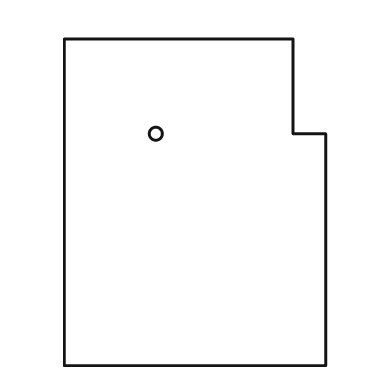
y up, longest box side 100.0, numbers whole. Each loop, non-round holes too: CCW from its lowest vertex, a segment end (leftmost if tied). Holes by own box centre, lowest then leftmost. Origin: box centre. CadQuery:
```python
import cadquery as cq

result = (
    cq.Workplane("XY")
    .moveTo(-40.0, -50.0)
    .lineTo(40.0, -50.0)
    .lineTo(40.0, 21.0)
    .lineTo(30.0, 21.0)
    .lineTo(30.0, 50.0)
    .lineTo(-40.0, 50.0)
    .close()
    .moveTo(-12.0, 21.0)
    .circle(2.0)
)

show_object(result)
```